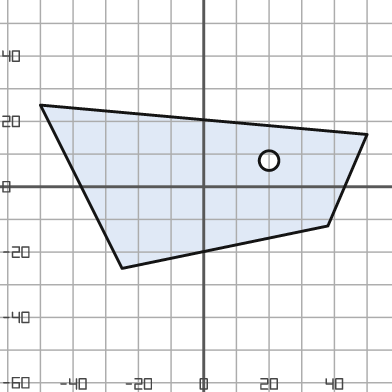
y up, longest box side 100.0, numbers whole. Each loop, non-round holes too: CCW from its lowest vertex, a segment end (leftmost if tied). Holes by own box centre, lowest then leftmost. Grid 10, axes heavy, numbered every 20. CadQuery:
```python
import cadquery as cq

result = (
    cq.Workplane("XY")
    .moveTo(-25.0, -25.0)
    .lineTo(38.0, -12.0)
    .lineTo(50.0, 16.0)
    .lineTo(-50.0, 25.0)
    .close()
    .moveTo(20.0, 8.0)
    .circle(3.0)
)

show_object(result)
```